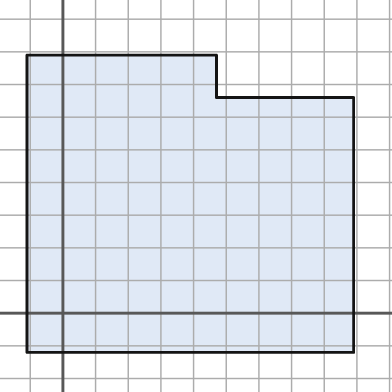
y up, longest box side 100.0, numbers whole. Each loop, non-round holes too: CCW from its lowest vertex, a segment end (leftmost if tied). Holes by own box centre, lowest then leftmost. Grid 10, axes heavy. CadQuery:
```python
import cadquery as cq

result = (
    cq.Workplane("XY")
    .moveTo(-11.0, -12.0)
    .lineTo(89.0, -12.0)
    .lineTo(89.0, 66.0)
    .lineTo(47.0, 66.0)
    .lineTo(47.0, 79.0)
    .lineTo(-11.0, 79.0)
    .close()
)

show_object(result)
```